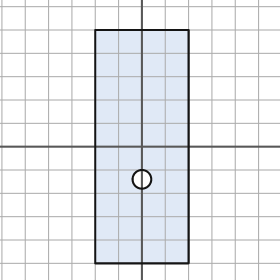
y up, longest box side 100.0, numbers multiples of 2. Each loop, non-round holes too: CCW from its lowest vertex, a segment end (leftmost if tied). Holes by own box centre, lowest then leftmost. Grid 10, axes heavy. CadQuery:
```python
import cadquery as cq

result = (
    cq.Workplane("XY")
    .moveTo(-20.0, -50.0)
    .lineTo(20.0, -50.0)
    .lineTo(20.0, 50.0)
    .lineTo(-20.0, 50.0)
    .close()
    .moveTo(0.0, -14.0)
    .circle(4.0)
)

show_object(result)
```